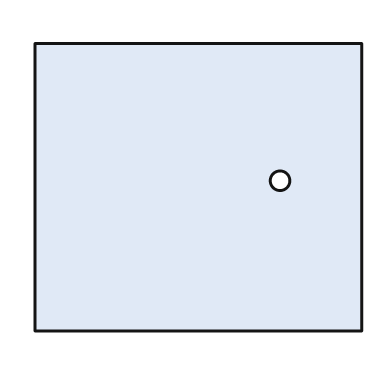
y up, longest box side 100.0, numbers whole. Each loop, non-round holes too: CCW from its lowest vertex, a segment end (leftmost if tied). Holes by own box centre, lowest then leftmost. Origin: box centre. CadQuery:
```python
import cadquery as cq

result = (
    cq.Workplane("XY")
    .moveTo(-50.0, -44.0)
    .lineTo(50.0, -44.0)
    .lineTo(50.0, 44.0)
    .lineTo(-50.0, 44.0)
    .close()
    .moveTo(25.0, 2.0)
    .circle(3.0)
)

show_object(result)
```